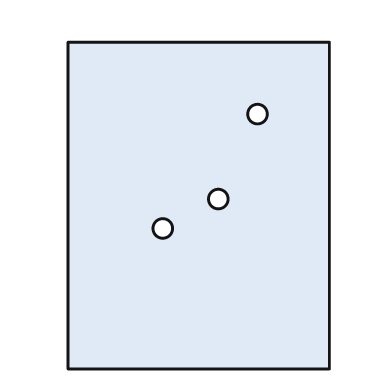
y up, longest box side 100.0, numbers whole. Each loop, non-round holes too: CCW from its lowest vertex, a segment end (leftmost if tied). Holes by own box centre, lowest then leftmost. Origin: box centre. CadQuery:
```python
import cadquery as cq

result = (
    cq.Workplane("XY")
    .moveTo(-40.0, -50.0)
    .lineTo(40.0, -50.0)
    .lineTo(40.0, 50.0)
    .lineTo(-40.0, 50.0)
    .close()
    .moveTo(-11.0, -7.0)
    .circle(3.0)
    .moveTo(6.0, 2.0)
    .circle(3.0)
    .moveTo(18.0, 28.0)
    .circle(3.0)
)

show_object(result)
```